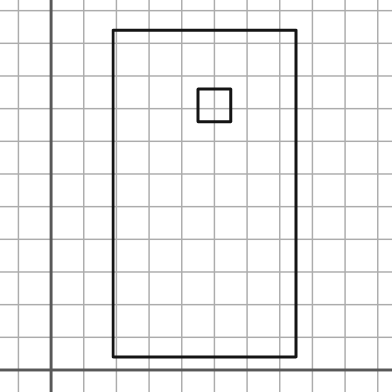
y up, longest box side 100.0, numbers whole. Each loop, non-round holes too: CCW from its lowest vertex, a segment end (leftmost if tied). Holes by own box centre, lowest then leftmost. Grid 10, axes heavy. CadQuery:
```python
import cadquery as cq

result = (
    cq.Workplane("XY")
    .moveTo(19.0, 4.0)
    .lineTo(75.0, 4.0)
    .lineTo(75.0, 104.0)
    .lineTo(19.0, 104.0)
    .close()
    .moveTo(45.0, 76.0)
    .lineTo(55.0, 76.0)
    .lineTo(55.0, 86.0)
    .lineTo(45.0, 86.0)
    .close()
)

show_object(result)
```